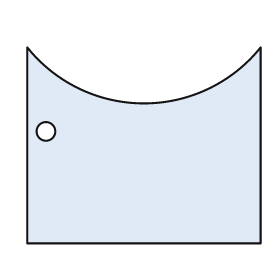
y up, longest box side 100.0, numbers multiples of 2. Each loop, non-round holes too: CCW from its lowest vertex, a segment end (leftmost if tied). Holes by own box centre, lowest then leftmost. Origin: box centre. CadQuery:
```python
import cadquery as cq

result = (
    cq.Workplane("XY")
    .moveTo(-50.0, -42.0)
    .lineTo(50.0, -42.0)
    .lineTo(50.0, 42.0)
    .threePointArc((0.0, 18.0), (-50.0, 42.0))
    .close()
    .moveTo(-42.0, 6.0)
    .circle(4.0)
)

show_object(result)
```